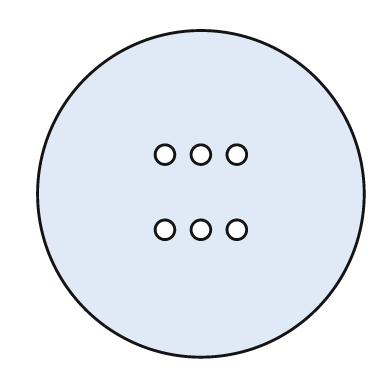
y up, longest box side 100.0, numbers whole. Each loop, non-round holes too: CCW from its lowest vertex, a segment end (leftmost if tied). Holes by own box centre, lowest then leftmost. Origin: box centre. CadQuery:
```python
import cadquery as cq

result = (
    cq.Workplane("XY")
    .moveTo(0.0, 0.0)
    .circle(50.0)
    .moveTo(-11.0, -11.0)
    .circle(3.0)
    .moveTo(0.0, -11.0)
    .circle(3.0)
    .moveTo(11.0, -11.0)
    .circle(3.0)
    .moveTo(-11.0, 12.0)
    .circle(3.0)
    .moveTo(0.0, 12.0)
    .circle(3.0)
    .moveTo(11.0, 12.0)
    .circle(3.0)
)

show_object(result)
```